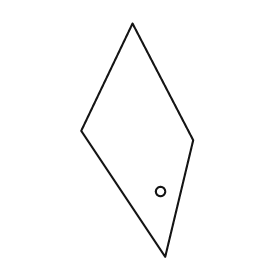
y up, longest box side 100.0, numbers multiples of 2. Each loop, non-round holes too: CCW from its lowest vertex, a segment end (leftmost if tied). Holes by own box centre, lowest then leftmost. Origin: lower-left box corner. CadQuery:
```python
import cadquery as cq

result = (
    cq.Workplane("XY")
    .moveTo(36.0, 0.0)
    .lineTo(48.0, 50.0)
    .lineTo(22.0, 100.0)
    .lineTo(0.0, 54.0)
    .close()
    .moveTo(34.0, 28.0)
    .circle(2.0)
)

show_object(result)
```